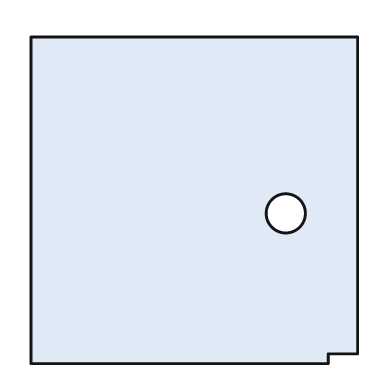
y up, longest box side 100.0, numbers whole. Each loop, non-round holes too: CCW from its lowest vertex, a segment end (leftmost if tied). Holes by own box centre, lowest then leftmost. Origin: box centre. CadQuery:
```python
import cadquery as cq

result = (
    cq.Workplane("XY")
    .moveTo(-50.0, -50.0)
    .lineTo(41.0, -50.0)
    .lineTo(41.0, -47.0)
    .lineTo(50.0, -47.0)
    .lineTo(50.0, 50.0)
    .lineTo(-50.0, 50.0)
    .close()
    .moveTo(28.0, -4.0)
    .circle(6.0)
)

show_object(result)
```